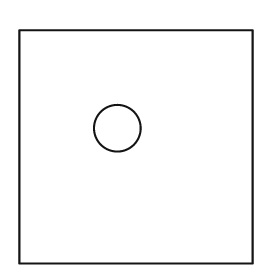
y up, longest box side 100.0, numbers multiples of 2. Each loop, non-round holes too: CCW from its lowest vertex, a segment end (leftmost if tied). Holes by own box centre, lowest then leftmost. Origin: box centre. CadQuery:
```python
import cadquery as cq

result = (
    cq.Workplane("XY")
    .moveTo(-50.0, -50.0)
    .lineTo(50.0, -50.0)
    .lineTo(50.0, 50.0)
    .lineTo(-50.0, 50.0)
    .close()
    .moveTo(-8.0, 8.0)
    .circle(10.0)
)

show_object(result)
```